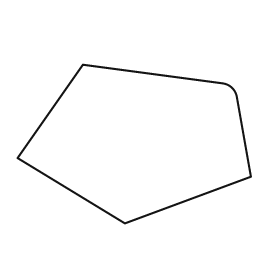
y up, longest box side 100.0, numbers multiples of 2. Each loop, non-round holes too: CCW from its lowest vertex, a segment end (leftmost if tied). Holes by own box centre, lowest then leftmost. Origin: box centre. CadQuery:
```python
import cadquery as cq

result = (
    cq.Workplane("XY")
    .moveTo(-4.0, -34.0)
    .lineTo(50.0, -14.0)
    .lineTo(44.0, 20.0)
    .threePointArc((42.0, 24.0), (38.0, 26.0))
    .lineTo(-22.0, 34.0)
    .lineTo(-50.0, -6.0)
    .close()
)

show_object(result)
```